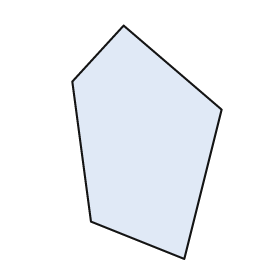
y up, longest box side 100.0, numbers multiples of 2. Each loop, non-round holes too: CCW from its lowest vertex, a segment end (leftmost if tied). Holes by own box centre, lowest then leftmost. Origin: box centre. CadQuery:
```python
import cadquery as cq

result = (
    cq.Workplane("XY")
    .moveTo(16.0, -50.0)
    .lineTo(32.0, 14.0)
    .lineTo(-10.0, 50.0)
    .lineTo(-32.0, 26.0)
    .lineTo(-24.0, -34.0)
    .close()
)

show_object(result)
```